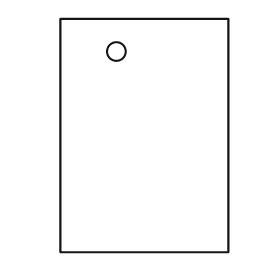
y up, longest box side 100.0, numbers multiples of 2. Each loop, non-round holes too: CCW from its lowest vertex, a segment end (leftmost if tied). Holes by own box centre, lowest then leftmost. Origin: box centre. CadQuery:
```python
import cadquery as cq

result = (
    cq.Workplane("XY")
    .moveTo(-36.0, -50.0)
    .lineTo(36.0, -50.0)
    .lineTo(36.0, 50.0)
    .lineTo(-36.0, 50.0)
    .close()
    .moveTo(-12.0, 36.0)
    .circle(4.0)
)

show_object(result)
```